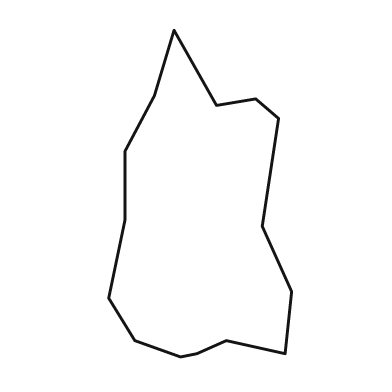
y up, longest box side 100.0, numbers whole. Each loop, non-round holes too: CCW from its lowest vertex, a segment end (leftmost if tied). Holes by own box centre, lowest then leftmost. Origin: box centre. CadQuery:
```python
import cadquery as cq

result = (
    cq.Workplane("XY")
    .moveTo(-6.0, -50.0)
    .lineTo(-1.0, -49.0)
    .lineTo(8.0, -45.0)
    .lineTo(26.0, -49.0)
    .lineTo(28.0, -30.0)
    .lineTo(19.0, -10.0)
    .lineTo(24.0, 23.0)
    .lineTo(17.0, 29.0)
    .lineTo(5.0, 27.0)
    .lineTo(-8.0, 50.0)
    .lineTo(-14.0, 30.0)
    .lineTo(-23.0, 13.0)
    .lineTo(-23.0, -8.0)
    .lineTo(-28.0, -32.0)
    .lineTo(-20.0, -45.0)
    .close()
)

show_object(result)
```